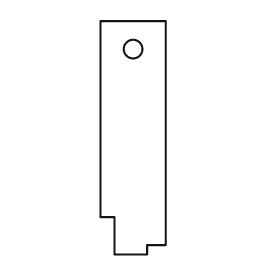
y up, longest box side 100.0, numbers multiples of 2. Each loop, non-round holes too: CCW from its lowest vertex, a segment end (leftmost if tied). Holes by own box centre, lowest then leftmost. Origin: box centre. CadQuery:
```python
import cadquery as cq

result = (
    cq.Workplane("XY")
    .moveTo(-8.0, -50.0)
    .lineTo(6.0, -50.0)
    .lineTo(6.0, -46.0)
    .lineTo(14.0, -46.0)
    .lineTo(14.0, 50.0)
    .lineTo(-14.0, 50.0)
    .lineTo(-14.0, -34.0)
    .lineTo(-8.0, -34.0)
    .close()
    .moveTo(0.0, 38.0)
    .circle(4.0)
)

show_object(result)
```